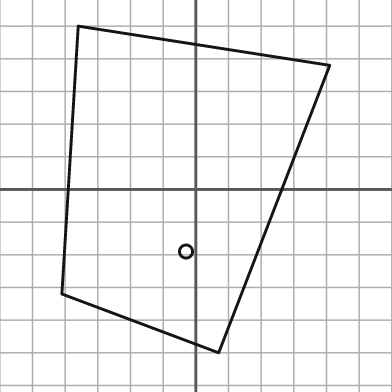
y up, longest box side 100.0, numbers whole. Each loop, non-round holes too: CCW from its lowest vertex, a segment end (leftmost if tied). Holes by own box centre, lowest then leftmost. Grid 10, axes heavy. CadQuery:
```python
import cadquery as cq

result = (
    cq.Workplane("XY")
    .moveTo(7.0, -50.0)
    .lineTo(41.0, 38.0)
    .lineTo(-36.0, 50.0)
    .lineTo(-41.0, -32.0)
    .close()
    .moveTo(-3.0, -19.0)
    .circle(2.0)
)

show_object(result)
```